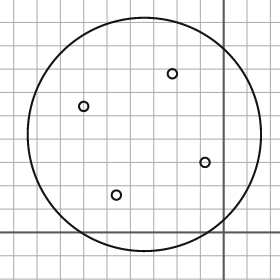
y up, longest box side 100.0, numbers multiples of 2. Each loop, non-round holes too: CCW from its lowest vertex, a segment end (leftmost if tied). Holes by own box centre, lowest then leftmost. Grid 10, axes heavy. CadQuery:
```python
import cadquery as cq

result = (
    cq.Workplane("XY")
    .moveTo(-34.0, 42.0)
    .circle(50.0)
    .moveTo(-46.0, 16.0)
    .circle(2.0)
    .moveTo(-8.0, 30.0)
    .circle(2.0)
    .moveTo(-60.0, 54.0)
    .circle(2.0)
    .moveTo(-22.0, 68.0)
    .circle(2.0)
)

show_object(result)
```